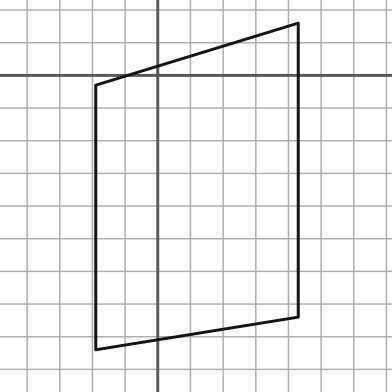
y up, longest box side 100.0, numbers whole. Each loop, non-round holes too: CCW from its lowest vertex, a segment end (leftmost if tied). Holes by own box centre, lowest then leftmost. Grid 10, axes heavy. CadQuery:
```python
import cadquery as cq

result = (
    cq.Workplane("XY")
    .moveTo(-19.0, -84.0)
    .lineTo(43.0, -74.0)
    .lineTo(43.0, 16.0)
    .lineTo(-19.0, -3.0)
    .close()
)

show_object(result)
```